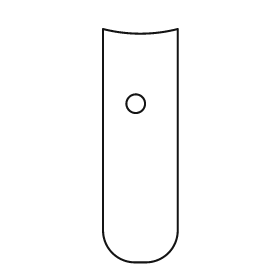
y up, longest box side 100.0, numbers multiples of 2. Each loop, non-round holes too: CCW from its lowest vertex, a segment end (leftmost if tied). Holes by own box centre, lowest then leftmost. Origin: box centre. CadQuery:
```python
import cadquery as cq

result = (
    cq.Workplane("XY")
    .moveTo(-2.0, -50.0)
    .lineTo(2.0, -50.0)
    .threePointArc((12.0, -46.0), (16.0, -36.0))
    .lineTo(16.0, 50.0)
    .threePointArc((0.0, 48.0), (-16.0, 50.0))
    .lineTo(-16.0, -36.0)
    .threePointArc((-12.0, -46.0), (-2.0, -50.0))
    .close()
    .moveTo(-2.0, 18.0)
    .circle(4.0)
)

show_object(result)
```